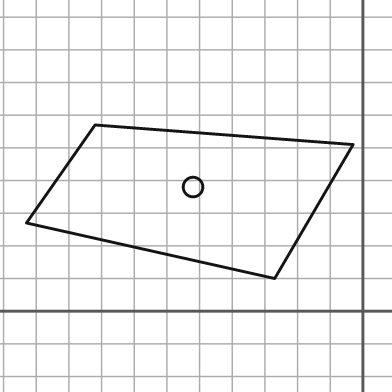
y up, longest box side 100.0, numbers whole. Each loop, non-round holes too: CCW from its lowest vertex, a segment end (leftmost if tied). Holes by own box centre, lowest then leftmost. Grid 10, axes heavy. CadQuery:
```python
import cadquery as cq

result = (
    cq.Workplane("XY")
    .moveTo(-27.0, 10.0)
    .lineTo(-3.0, 51.0)
    .lineTo(-82.0, 57.0)
    .lineTo(-103.0, 27.0)
    .close()
    .moveTo(-52.0, 38.0)
    .circle(3.0)
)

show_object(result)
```